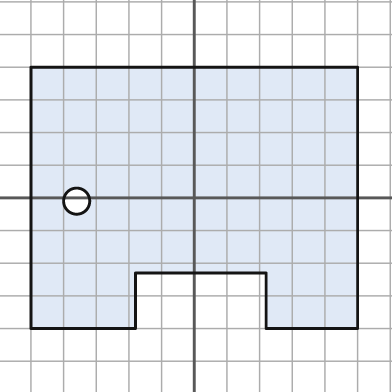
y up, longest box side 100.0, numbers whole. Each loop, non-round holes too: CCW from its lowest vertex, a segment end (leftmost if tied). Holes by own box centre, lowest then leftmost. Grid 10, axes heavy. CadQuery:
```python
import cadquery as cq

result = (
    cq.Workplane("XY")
    .moveTo(-50.0, -40.0)
    .lineTo(-18.0, -40.0)
    .lineTo(-18.0, -23.0)
    .lineTo(22.0, -23.0)
    .lineTo(22.0, -40.0)
    .lineTo(50.0, -40.0)
    .lineTo(50.0, 40.0)
    .lineTo(-50.0, 40.0)
    .close()
    .moveTo(-36.0, -1.0)
    .circle(4.0)
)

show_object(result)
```